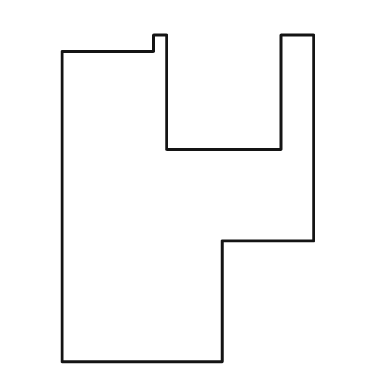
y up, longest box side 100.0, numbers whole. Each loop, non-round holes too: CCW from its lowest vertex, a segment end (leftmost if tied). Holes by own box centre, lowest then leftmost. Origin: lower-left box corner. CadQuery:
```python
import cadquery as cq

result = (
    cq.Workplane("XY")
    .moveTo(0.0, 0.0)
    .lineTo(49.0, 0.0)
    .lineTo(49.0, 37.0)
    .lineTo(77.0, 37.0)
    .lineTo(77.0, 100.0)
    .lineTo(67.0, 100.0)
    .lineTo(67.0, 65.0)
    .lineTo(32.0, 65.0)
    .lineTo(32.0, 100.0)
    .lineTo(28.0, 100.0)
    .lineTo(28.0, 95.0)
    .lineTo(0.0, 95.0)
    .close()
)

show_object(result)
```